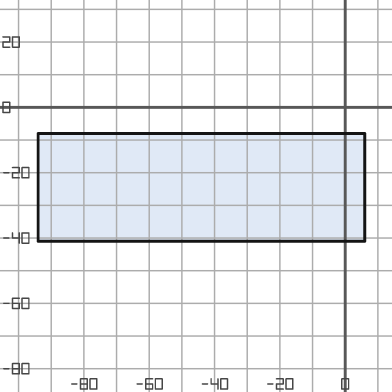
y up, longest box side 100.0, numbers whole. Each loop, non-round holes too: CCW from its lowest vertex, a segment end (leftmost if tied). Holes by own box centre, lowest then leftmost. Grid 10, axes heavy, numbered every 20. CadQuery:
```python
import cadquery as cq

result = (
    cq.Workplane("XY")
    .moveTo(-94.0, -41.0)
    .lineTo(6.0, -41.0)
    .lineTo(6.0, -8.0)
    .lineTo(-94.0, -8.0)
    .close()
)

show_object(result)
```